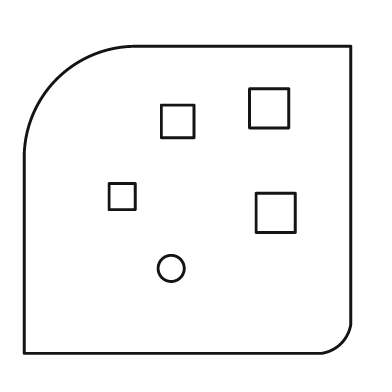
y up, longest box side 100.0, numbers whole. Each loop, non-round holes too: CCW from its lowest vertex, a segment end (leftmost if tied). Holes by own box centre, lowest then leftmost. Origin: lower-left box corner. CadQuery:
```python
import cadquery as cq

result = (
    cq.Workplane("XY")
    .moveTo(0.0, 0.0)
    .lineTo(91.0, 0.0)
    .threePointArc((97.0, 3.0), (100.0, 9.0))
    .lineTo(100.0, 94.0)
    .lineTo(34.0, 94.0)
    .threePointArc((10.0, 84.0), (0.0, 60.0))
    .close()
    .moveTo(45.0, 26.0)
    .circle(4.0)
    .moveTo(71.0, 37.0)
    .lineTo(83.0, 37.0)
    .lineTo(83.0, 49.0)
    .lineTo(71.0, 49.0)
    .close()
    .moveTo(26.0, 44.0)
    .lineTo(34.0, 44.0)
    .lineTo(34.0, 52.0)
    .lineTo(26.0, 52.0)
    .close()
    .moveTo(42.0, 66.0)
    .lineTo(52.0, 66.0)
    .lineTo(52.0, 76.0)
    .lineTo(42.0, 76.0)
    .close()
    .moveTo(69.0, 69.0)
    .lineTo(81.0, 69.0)
    .lineTo(81.0, 81.0)
    .lineTo(69.0, 81.0)
    .close()
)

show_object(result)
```